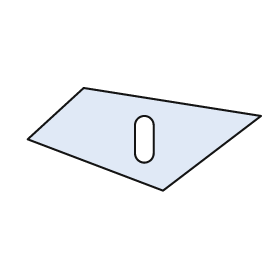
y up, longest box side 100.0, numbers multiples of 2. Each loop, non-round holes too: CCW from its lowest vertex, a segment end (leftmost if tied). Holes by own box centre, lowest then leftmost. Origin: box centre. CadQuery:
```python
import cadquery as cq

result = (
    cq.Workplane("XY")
    .moveTo(8.0, -22.0)
    .lineTo(50.0, 10.0)
    .lineTo(-26.0, 22.0)
    .lineTo(-50.0, 0.0)
    .close()
    .moveTo(-4.0, -6.0)
    .threePointArc((0.0, -10.0), (4.0, -6.0))
    .lineTo(4.0, 6.0)
    .threePointArc((0.0, 10.0), (-4.0, 6.0))
    .close()
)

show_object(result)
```